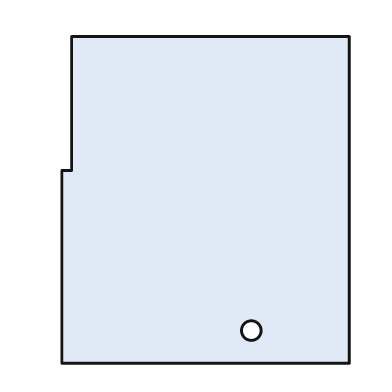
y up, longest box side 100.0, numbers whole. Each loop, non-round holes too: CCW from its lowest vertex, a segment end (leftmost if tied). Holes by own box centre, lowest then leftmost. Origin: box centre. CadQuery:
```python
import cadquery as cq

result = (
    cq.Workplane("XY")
    .moveTo(-44.0, -50.0)
    .lineTo(44.0, -50.0)
    .lineTo(44.0, 50.0)
    .lineTo(-41.0, 50.0)
    .lineTo(-41.0, 9.0)
    .lineTo(-44.0, 9.0)
    .close()
    .moveTo(14.0, -40.0)
    .circle(3.0)
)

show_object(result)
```